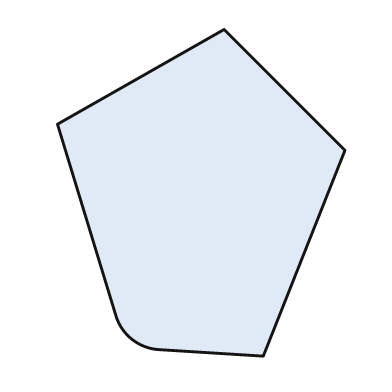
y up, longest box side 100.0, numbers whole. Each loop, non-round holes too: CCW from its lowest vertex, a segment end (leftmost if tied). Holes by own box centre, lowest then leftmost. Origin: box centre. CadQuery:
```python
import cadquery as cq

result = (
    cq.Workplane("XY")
    .moveTo(19.0, -50.0)
    .lineTo(44.0, 13.0)
    .lineTo(7.0, 50.0)
    .lineTo(-44.0, 21.0)
    .lineTo(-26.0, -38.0)
    .threePointArc((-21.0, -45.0), (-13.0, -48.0))
    .close()
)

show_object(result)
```